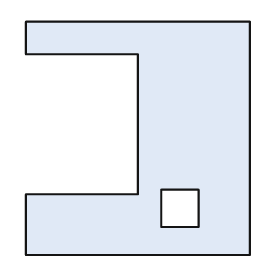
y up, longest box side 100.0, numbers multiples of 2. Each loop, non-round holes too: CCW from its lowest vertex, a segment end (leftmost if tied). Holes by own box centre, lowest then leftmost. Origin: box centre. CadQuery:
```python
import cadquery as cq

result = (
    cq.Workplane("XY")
    .moveTo(-48.0, -50.0)
    .lineTo(48.0, -50.0)
    .lineTo(48.0, 50.0)
    .lineTo(-48.0, 50.0)
    .lineTo(-48.0, 36.0)
    .lineTo(0.0, 36.0)
    .lineTo(0.0, -24.0)
    .lineTo(-48.0, -24.0)
    .close()
    .moveTo(10.0, -38.0)
    .lineTo(26.0, -38.0)
    .lineTo(26.0, -22.0)
    .lineTo(10.0, -22.0)
    .close()
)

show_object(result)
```